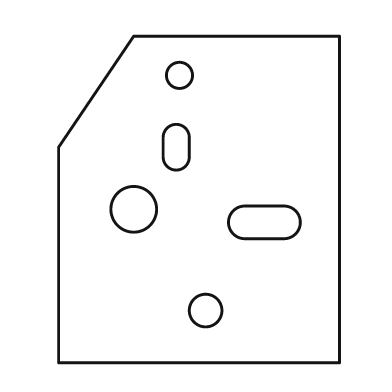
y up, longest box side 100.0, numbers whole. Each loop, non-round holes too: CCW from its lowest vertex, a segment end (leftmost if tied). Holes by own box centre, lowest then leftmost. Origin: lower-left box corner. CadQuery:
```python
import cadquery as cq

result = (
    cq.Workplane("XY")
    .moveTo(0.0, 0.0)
    .lineTo(86.0, 0.0)
    .lineTo(86.0, 100.0)
    .lineTo(23.0, 100.0)
    .lineTo(0.0, 66.0)
    .close()
    .moveTo(45.0, 16.0)
    .circle(5.0)
    .moveTo(57.0, 38.0)
    .lineTo(69.0, 38.0)
    .threePointArc((74.0, 43.0), (69.0, 48.0))
    .lineTo(57.0, 48.0)
    .threePointArc((52.0, 43.0), (57.0, 38.0))
    .close()
    .moveTo(23.0, 47.0)
    .circle(7.0)
    .moveTo(32.0, 63.0)
    .threePointArc((36.0, 59.0), (40.0, 63.0))
    .lineTo(40.0, 69.0)
    .threePointArc((36.0, 73.0), (32.0, 69.0))
    .close()
    .moveTo(37.0, 88.0)
    .circle(4.0)
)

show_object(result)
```